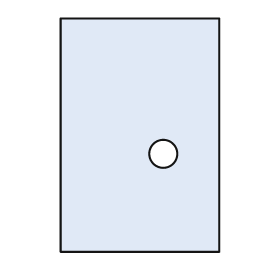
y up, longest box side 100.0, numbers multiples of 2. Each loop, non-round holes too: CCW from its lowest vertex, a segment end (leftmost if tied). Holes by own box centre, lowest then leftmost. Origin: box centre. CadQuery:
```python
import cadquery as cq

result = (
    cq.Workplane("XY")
    .moveTo(-34.0, -50.0)
    .lineTo(34.0, -50.0)
    .lineTo(34.0, 50.0)
    .lineTo(-34.0, 50.0)
    .close()
    .moveTo(10.0, -8.0)
    .circle(6.0)
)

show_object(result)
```